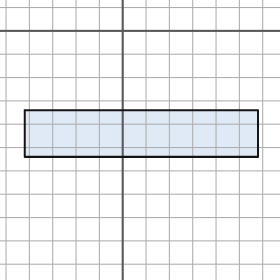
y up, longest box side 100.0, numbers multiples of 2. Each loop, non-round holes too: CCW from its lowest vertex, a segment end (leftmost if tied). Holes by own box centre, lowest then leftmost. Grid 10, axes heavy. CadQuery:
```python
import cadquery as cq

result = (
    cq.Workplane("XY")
    .moveTo(-42.0, -54.0)
    .lineTo(58.0, -54.0)
    .lineTo(58.0, -34.0)
    .lineTo(-42.0, -34.0)
    .close()
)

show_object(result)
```